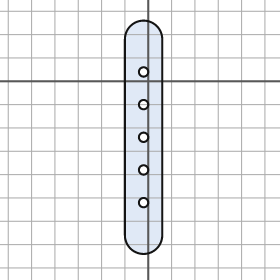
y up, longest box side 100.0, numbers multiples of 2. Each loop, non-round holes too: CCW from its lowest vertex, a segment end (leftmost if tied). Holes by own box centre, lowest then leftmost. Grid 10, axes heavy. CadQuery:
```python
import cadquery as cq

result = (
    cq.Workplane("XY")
    .moveTo(-10.0, -66.0)
    .threePointArc((-2.0, -74.0), (6.0, -66.0))
    .lineTo(6.0, 18.0)
    .threePointArc((-2.0, 26.0), (-10.0, 18.0))
    .close()
    .moveTo(-2.0, -52.0)
    .circle(2.0)
    .moveTo(-2.0, -38.0)
    .circle(2.0)
    .moveTo(-2.0, -24.0)
    .circle(2.0)
    .moveTo(-2.0, -10.0)
    .circle(2.0)
    .moveTo(-2.0, 4.0)
    .circle(2.0)
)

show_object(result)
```